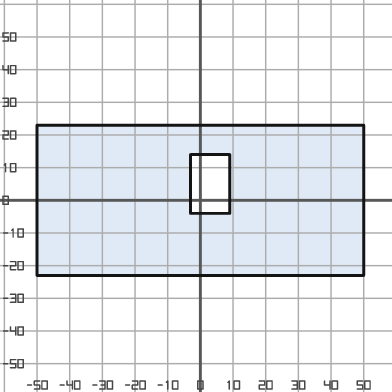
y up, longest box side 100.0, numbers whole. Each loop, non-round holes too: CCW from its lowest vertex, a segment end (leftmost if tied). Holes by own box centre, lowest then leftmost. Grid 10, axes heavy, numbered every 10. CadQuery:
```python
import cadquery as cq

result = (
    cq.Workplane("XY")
    .moveTo(-50.0, -23.0)
    .lineTo(50.0, -23.0)
    .lineTo(50.0, 23.0)
    .lineTo(-50.0, 23.0)
    .close()
    .moveTo(-3.0, -4.0)
    .lineTo(9.0, -4.0)
    .lineTo(9.0, 14.0)
    .lineTo(-3.0, 14.0)
    .close()
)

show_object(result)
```